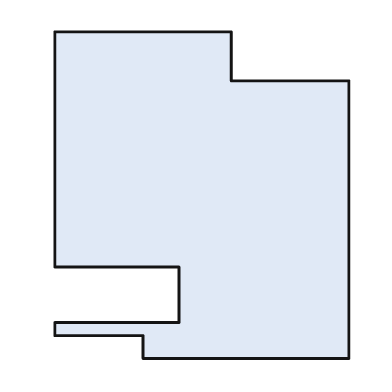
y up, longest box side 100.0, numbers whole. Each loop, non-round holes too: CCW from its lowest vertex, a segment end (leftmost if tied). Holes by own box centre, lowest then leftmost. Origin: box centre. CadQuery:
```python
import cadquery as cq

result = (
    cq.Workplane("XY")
    .moveTo(-18.0, -50.0)
    .lineTo(45.0, -50.0)
    .lineTo(45.0, 35.0)
    .lineTo(9.0, 35.0)
    .lineTo(9.0, 50.0)
    .lineTo(-45.0, 50.0)
    .lineTo(-45.0, -22.0)
    .lineTo(-7.0, -22.0)
    .lineTo(-7.0, -39.0)
    .lineTo(-45.0, -39.0)
    .lineTo(-45.0, -43.0)
    .lineTo(-18.0, -43.0)
    .close()
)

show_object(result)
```